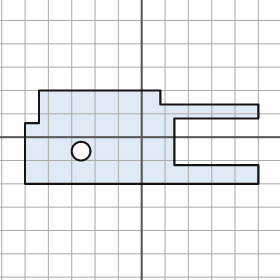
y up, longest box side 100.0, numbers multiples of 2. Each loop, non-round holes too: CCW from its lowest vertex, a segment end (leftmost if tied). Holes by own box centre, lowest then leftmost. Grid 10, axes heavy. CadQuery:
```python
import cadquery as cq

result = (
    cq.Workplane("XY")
    .moveTo(-50.0, -20.0)
    .lineTo(50.0, -20.0)
    .lineTo(50.0, -12.0)
    .lineTo(14.0, -12.0)
    .lineTo(14.0, 8.0)
    .lineTo(50.0, 8.0)
    .lineTo(50.0, 14.0)
    .lineTo(8.0, 14.0)
    .lineTo(8.0, 20.0)
    .lineTo(-44.0, 20.0)
    .lineTo(-44.0, 6.0)
    .lineTo(-50.0, 6.0)
    .close()
    .moveTo(-26.0, -6.0)
    .circle(4.0)
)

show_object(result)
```